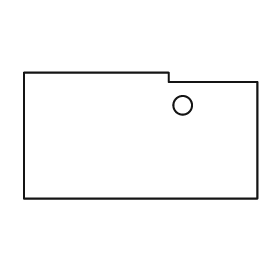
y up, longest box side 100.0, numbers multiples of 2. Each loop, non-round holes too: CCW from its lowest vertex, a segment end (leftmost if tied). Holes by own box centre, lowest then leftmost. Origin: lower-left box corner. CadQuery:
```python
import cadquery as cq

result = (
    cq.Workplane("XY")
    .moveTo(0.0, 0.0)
    .lineTo(100.0, 0.0)
    .lineTo(100.0, 50.0)
    .lineTo(62.0, 50.0)
    .lineTo(62.0, 54.0)
    .lineTo(0.0, 54.0)
    .close()
    .moveTo(68.0, 40.0)
    .circle(4.0)
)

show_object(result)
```